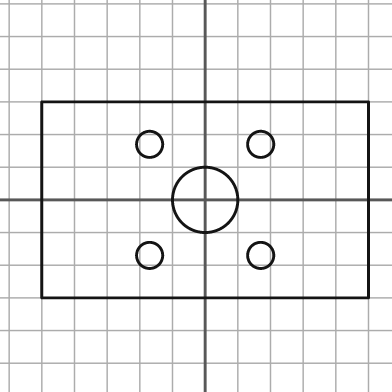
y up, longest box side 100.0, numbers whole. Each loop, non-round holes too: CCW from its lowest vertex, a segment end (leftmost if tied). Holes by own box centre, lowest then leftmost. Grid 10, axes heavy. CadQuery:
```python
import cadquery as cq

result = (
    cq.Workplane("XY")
    .moveTo(-50.0, -30.0)
    .lineTo(50.0, -30.0)
    .lineTo(50.0, 30.0)
    .lineTo(-50.0, 30.0)
    .close()
    .moveTo(-17.0, -17.0)
    .circle(4.0)
    .moveTo(17.0, -17.0)
    .circle(4.0)
    .moveTo(0.0, 0.0)
    .circle(10.0)
    .moveTo(-17.0, 17.0)
    .circle(4.0)
    .moveTo(17.0, 17.0)
    .circle(4.0)
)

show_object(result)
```